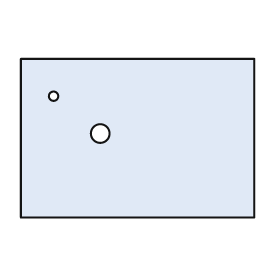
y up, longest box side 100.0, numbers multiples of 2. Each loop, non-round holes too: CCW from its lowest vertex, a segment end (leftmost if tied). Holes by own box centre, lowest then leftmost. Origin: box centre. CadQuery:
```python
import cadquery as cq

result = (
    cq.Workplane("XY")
    .moveTo(-50.0, -34.0)
    .lineTo(50.0, -34.0)
    .lineTo(50.0, 34.0)
    .lineTo(-50.0, 34.0)
    .close()
    .moveTo(-16.0, 2.0)
    .circle(4.0)
    .moveTo(-36.0, 18.0)
    .circle(2.0)
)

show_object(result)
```